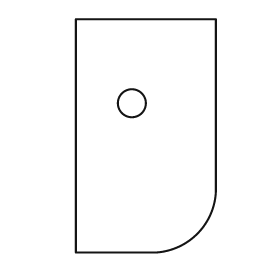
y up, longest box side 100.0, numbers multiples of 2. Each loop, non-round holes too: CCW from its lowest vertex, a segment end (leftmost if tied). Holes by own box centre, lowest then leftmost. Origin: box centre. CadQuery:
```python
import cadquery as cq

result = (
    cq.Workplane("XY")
    .moveTo(-30.0, -50.0)
    .lineTo(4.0, -50.0)
    .threePointArc((22.0, -42.0), (30.0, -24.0))
    .lineTo(30.0, 50.0)
    .lineTo(-30.0, 50.0)
    .close()
    .moveTo(-6.0, 14.0)
    .circle(6.0)
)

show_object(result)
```